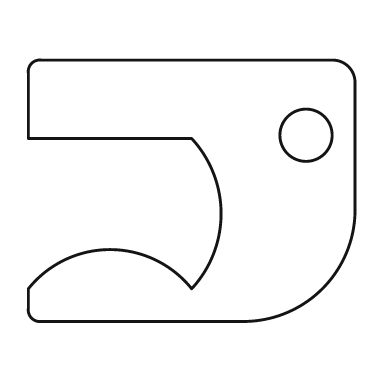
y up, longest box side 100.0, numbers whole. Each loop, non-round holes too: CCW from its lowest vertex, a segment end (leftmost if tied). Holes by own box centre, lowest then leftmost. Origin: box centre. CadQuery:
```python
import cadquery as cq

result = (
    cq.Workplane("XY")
    .moveTo(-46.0, -40.0)
    .lineTo(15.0, -40.0)
    .threePointArc((40.0, -30.0), (50.0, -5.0))
    .lineTo(50.0, 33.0)
    .threePointArc((48.0, 38.0), (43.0, 40.0))
    .lineTo(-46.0, 40.0)
    .threePointArc((-49.0, 39.0), (-50.0, 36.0))
    .lineTo(-50.0, 16.0)
    .lineTo(0.0, 16.0)
    .threePointArc((9.0, -7.0), (0.0, -30.0))
    .threePointArc((-25.0, -18.0), (-50.0, -30.0))
    .lineTo(-50.0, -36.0)
    .threePointArc((-49.0, -39.0), (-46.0, -40.0))
    .close()
    .moveTo(35.0, 17.0)
    .circle(8.0)
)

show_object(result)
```